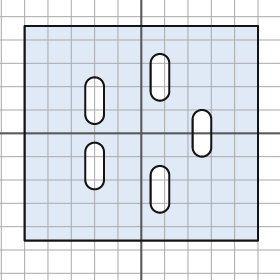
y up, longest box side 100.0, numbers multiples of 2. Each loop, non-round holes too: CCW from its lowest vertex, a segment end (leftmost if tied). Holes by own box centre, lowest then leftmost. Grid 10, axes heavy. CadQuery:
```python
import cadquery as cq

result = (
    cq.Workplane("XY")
    .moveTo(-50.0, -46.0)
    .lineTo(50.0, -46.0)
    .lineTo(50.0, 46.0)
    .lineTo(-50.0, 46.0)
    .close()
    .moveTo(4.0, -30.0)
    .threePointArc((8.0, -34.0), (12.0, -30.0))
    .lineTo(12.0, -18.0)
    .threePointArc((8.0, -14.0), (4.0, -18.0))
    .close()
    .moveTo(-24.0, -20.0)
    .threePointArc((-20.0, -24.0), (-16.0, -20.0))
    .lineTo(-16.0, -8.0)
    .threePointArc((-20.0, -4.0), (-24.0, -8.0))
    .close()
    .moveTo(22.0, -6.0)
    .threePointArc((26.0, -10.0), (30.0, -6.0))
    .lineTo(30.0, 6.0)
    .threePointArc((26.0, 10.0), (22.0, 6.0))
    .close()
    .moveTo(-24.0, 8.0)
    .threePointArc((-20.0, 4.0), (-16.0, 8.0))
    .lineTo(-16.0, 20.0)
    .threePointArc((-20.0, 24.0), (-24.0, 20.0))
    .close()
    .moveTo(4.0, 18.0)
    .threePointArc((8.0, 14.0), (12.0, 18.0))
    .lineTo(12.0, 30.0)
    .threePointArc((8.0, 34.0), (4.0, 30.0))
    .close()
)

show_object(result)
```